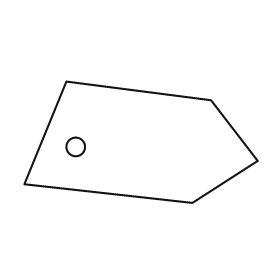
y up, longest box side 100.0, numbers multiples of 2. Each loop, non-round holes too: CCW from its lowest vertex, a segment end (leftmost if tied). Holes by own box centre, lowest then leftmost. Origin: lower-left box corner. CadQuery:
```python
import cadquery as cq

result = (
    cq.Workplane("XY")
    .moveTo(72.0, 0.0)
    .lineTo(100.0, 18.0)
    .lineTo(80.0, 44.0)
    .lineTo(18.0, 52.0)
    .lineTo(0.0, 8.0)
    .close()
    .moveTo(22.0, 24.0)
    .circle(4.0)
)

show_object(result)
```